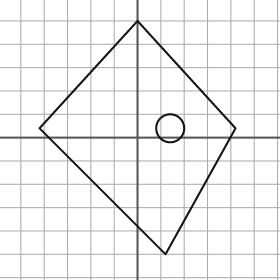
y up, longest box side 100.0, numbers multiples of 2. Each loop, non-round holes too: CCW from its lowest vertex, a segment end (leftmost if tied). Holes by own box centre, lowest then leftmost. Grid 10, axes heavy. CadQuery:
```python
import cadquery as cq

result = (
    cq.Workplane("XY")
    .moveTo(12.0, -50.0)
    .lineTo(42.0, 4.0)
    .lineTo(0.0, 50.0)
    .lineTo(-42.0, 4.0)
    .close()
    .moveTo(14.0, 4.0)
    .circle(6.0)
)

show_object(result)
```